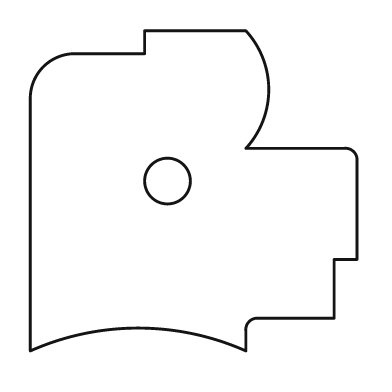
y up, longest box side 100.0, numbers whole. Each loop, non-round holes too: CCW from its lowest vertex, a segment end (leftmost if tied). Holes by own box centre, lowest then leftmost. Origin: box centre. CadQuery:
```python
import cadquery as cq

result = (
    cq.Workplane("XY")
    .moveTo(-50.0, -49.0)
    .threePointArc((-17.0, -42.0), (16.0, -49.0))
    .lineTo(16.0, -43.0)
    .threePointArc((17.0, -40.0), (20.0, -39.0))
    .lineTo(43.0, -39.0)
    .lineTo(43.0, -21.0)
    .lineTo(50.0, -21.0)
    .lineTo(50.0, 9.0)
    .threePointArc((49.0, 12.0), (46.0, 13.0))
    .lineTo(16.0, 13.0)
    .threePointArc((23.0, 31.0), (16.0, 49.0))
    .lineTo(-15.0, 49.0)
    .lineTo(-15.0, 42.0)
    .lineTo(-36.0, 42.0)
    .threePointArc((-46.0, 38.0), (-50.0, 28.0))
    .close()
    .moveTo(-8.0, 3.0)
    .circle(7.0)
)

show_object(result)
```